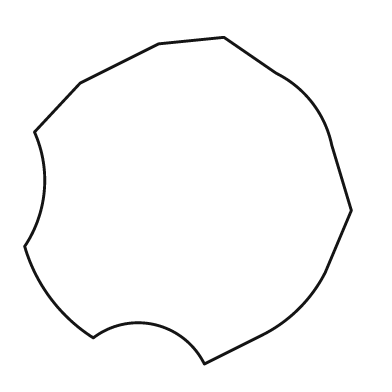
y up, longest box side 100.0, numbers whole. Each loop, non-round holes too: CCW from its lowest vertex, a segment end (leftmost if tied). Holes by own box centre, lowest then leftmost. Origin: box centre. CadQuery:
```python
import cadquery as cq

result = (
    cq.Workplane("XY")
    .moveTo(5.0, -50.0)
    .lineTo(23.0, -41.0)
    .threePointArc((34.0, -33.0), (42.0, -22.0))
    .lineTo(50.0, -3.0)
    .lineTo(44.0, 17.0)
    .threePointArc((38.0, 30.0), (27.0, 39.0))
    .lineTo(11.0, 50.0)
    .lineTo(-9.0, 48.0)
    .lineTo(-33.0, 36.0)
    .lineTo(-47.0, 21.0)
    .threePointArc((-44.0, 3.0), (-50.0, -14.0))
    .threePointArc((-42.0, -30.0), (-29.0, -42.0))
    .threePointArc((-10.0, -38.0), (5.0, -50.0))
    .close()
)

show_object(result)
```